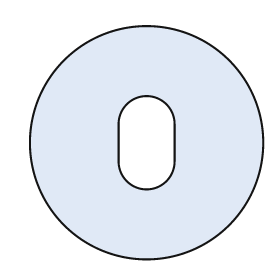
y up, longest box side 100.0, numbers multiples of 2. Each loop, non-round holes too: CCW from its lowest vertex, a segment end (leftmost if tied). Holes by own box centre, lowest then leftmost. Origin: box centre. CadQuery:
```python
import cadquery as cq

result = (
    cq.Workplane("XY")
    .moveTo(0.0, 0.0)
    .circle(50.0)
    .moveTo(-12.0, -8.0)
    .threePointArc((0.0, -20.0), (12.0, -8.0))
    .lineTo(12.0, 8.0)
    .threePointArc((0.0, 20.0), (-12.0, 8.0))
    .close()
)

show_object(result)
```